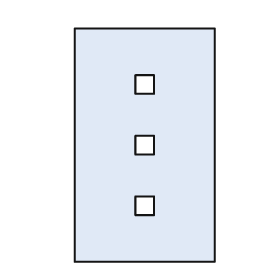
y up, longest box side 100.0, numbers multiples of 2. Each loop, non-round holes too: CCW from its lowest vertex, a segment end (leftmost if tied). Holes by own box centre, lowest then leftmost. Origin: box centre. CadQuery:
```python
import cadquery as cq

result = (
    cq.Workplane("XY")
    .moveTo(-30.0, -50.0)
    .lineTo(30.0, -50.0)
    .lineTo(30.0, 50.0)
    .lineTo(-30.0, 50.0)
    .close()
    .moveTo(-4.0, -30.0)
    .lineTo(4.0, -30.0)
    .lineTo(4.0, -22.0)
    .lineTo(-4.0, -22.0)
    .close()
    .moveTo(-4.0, -4.0)
    .lineTo(4.0, -4.0)
    .lineTo(4.0, 4.0)
    .lineTo(-4.0, 4.0)
    .close()
    .moveTo(-4.0, 22.0)
    .lineTo(4.0, 22.0)
    .lineTo(4.0, 30.0)
    .lineTo(-4.0, 30.0)
    .close()
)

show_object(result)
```